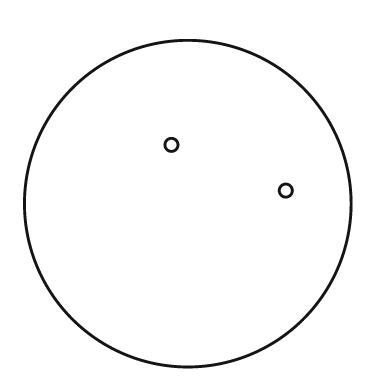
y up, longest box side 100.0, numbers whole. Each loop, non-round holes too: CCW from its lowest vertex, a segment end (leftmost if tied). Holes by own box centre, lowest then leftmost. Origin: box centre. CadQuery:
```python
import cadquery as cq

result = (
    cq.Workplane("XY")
    .moveTo(0.0, 0.0)
    .circle(50.0)
    .moveTo(30.0, 4.0)
    .circle(2.0)
    .moveTo(-5.0, 18.0)
    .circle(2.0)
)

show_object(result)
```